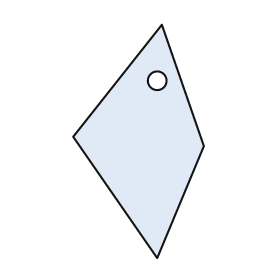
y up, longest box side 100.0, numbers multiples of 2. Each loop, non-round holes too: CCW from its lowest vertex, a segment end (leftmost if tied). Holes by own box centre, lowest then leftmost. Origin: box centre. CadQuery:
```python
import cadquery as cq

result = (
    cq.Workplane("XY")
    .moveTo(8.0, -50.0)
    .lineTo(28.0, -2.0)
    .lineTo(10.0, 50.0)
    .lineTo(-28.0, 2.0)
    .close()
    .moveTo(8.0, 26.0)
    .circle(4.0)
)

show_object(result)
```